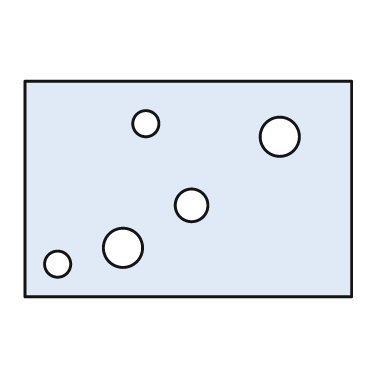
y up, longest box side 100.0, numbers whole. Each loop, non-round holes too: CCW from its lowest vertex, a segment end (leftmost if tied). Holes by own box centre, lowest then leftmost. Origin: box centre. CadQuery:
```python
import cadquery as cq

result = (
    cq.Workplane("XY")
    .moveTo(-50.0, -33.0)
    .lineTo(50.0, -33.0)
    .lineTo(50.0, 33.0)
    .lineTo(-50.0, 33.0)
    .close()
    .moveTo(-40.0, -23.0)
    .circle(4.0)
    .moveTo(-20.0, -18.0)
    .circle(6.0)
    .moveTo(1.0, -5.0)
    .circle(5.0)
    .moveTo(28.0, 16.0)
    .circle(6.0)
    .moveTo(-13.0, 20.0)
    .circle(4.0)
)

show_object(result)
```